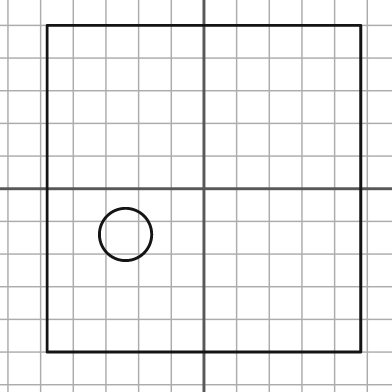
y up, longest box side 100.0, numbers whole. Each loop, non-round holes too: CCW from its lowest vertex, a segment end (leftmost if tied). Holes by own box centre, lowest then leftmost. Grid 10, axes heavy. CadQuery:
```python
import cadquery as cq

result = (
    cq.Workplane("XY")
    .moveTo(-48.0, -50.0)
    .lineTo(48.0, -50.0)
    .lineTo(48.0, 50.0)
    .lineTo(-48.0, 50.0)
    .close()
    .moveTo(-24.0, -14.0)
    .circle(8.0)
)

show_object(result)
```